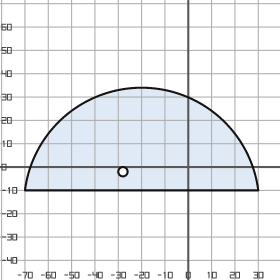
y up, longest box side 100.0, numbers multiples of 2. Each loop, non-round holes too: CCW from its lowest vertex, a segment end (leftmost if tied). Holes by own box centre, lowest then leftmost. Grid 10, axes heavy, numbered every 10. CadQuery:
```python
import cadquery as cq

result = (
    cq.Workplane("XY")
    .moveTo(-70.0, -10.0)
    .lineTo(30.0, -10.0)
    .threePointArc((-20.0, 34.0), (-70.0, -10.0))
    .close()
    .moveTo(-28.0, -2.0)
    .circle(2.0)
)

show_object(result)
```